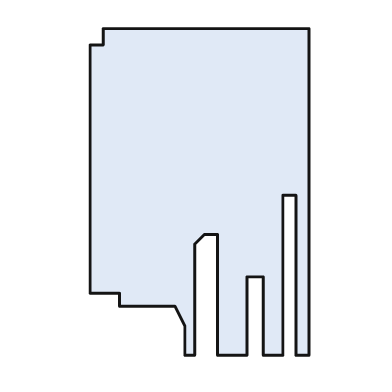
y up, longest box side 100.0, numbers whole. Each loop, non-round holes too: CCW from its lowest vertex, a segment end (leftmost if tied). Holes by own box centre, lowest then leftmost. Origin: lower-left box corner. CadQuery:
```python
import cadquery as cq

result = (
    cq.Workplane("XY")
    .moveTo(29.0, 0.0)
    .lineTo(32.0, 0.0)
    .lineTo(32.0, 34.0)
    .lineTo(35.0, 37.0)
    .lineTo(39.0, 37.0)
    .lineTo(39.0, 0.0)
    .lineTo(48.0, 0.0)
    .lineTo(48.0, 24.0)
    .lineTo(53.0, 24.0)
    .lineTo(53.0, 0.0)
    .lineTo(59.0, 0.0)
    .lineTo(59.0, 49.0)
    .lineTo(63.0, 49.0)
    .lineTo(63.0, 0.0)
    .lineTo(67.0, 0.0)
    .lineTo(67.0, 100.0)
    .lineTo(4.0, 100.0)
    .lineTo(4.0, 95.0)
    .lineTo(0.0, 95.0)
    .lineTo(0.0, 19.0)
    .lineTo(9.0, 19.0)
    .lineTo(9.0, 15.0)
    .lineTo(26.0, 15.0)
    .lineTo(29.0, 9.0)
    .close()
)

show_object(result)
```